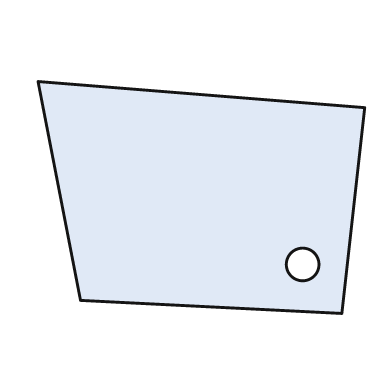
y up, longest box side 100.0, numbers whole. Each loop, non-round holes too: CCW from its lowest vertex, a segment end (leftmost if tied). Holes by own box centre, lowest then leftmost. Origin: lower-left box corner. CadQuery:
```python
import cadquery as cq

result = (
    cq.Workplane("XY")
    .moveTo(93.0, 0.0)
    .lineTo(100.0, 63.0)
    .lineTo(0.0, 71.0)
    .lineTo(13.0, 4.0)
    .close()
    .moveTo(81.0, 15.0)
    .circle(5.0)
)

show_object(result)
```